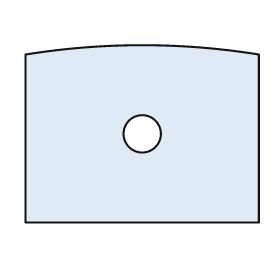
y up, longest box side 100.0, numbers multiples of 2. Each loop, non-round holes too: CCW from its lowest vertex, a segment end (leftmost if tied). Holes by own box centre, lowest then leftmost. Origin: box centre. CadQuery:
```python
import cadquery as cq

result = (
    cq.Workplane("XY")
    .moveTo(-50.0, -38.0)
    .lineTo(50.0, -38.0)
    .lineTo(50.0, 34.0)
    .threePointArc((0.0, 38.0), (-50.0, 34.0))
    .close()
    .moveTo(0.0, 0.0)
    .circle(8.0)
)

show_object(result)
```